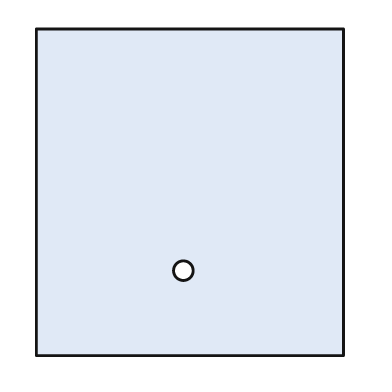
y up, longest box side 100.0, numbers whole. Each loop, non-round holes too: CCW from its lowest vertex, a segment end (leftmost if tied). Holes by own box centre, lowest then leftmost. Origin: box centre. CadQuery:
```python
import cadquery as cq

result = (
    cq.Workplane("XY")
    .moveTo(-47.0, -50.0)
    .lineTo(47.0, -50.0)
    .lineTo(47.0, 50.0)
    .lineTo(-47.0, 50.0)
    .close()
    .moveTo(-2.0, -24.0)
    .circle(3.0)
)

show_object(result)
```